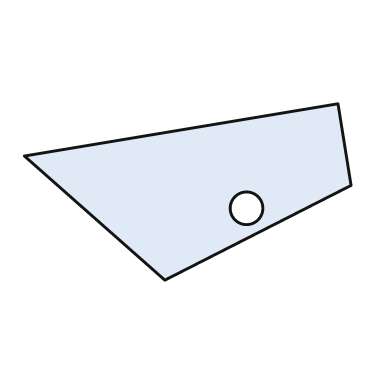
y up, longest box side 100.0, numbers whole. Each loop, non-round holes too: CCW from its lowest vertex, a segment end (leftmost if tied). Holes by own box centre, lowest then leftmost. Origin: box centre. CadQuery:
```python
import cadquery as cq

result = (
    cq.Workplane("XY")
    .moveTo(-7.0, -27.0)
    .lineTo(50.0, 2.0)
    .lineTo(46.0, 27.0)
    .lineTo(-50.0, 11.0)
    .close()
    .moveTo(18.0, -5.0)
    .circle(5.0)
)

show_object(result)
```